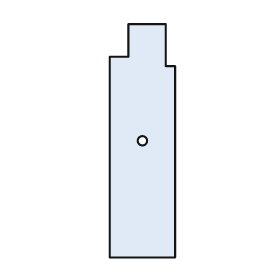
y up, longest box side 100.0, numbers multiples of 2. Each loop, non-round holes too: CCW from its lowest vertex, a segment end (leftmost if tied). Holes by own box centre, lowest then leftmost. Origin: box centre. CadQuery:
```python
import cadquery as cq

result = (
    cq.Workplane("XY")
    .moveTo(-14.0, -50.0)
    .lineTo(14.0, -50.0)
    .lineTo(14.0, 32.0)
    .lineTo(10.0, 32.0)
    .lineTo(10.0, 50.0)
    .lineTo(-6.0, 50.0)
    .lineTo(-6.0, 36.0)
    .lineTo(-14.0, 36.0)
    .close()
    .moveTo(0.0, 0.0)
    .circle(2.0)
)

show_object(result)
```